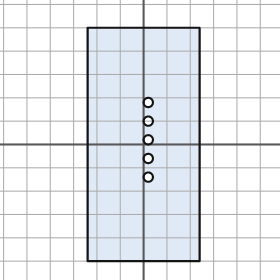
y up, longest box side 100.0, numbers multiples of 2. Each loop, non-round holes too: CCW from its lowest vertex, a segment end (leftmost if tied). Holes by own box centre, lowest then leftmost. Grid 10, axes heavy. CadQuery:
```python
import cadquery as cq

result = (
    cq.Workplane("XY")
    .moveTo(-24.0, -50.0)
    .lineTo(24.0, -50.0)
    .lineTo(24.0, 50.0)
    .lineTo(-24.0, 50.0)
    .close()
    .moveTo(2.0, -14.0)
    .circle(2.0)
    .moveTo(2.0, -6.0)
    .circle(2.0)
    .moveTo(2.0, 2.0)
    .circle(2.0)
    .moveTo(2.0, 10.0)
    .circle(2.0)
    .moveTo(2.0, 18.0)
    .circle(2.0)
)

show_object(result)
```